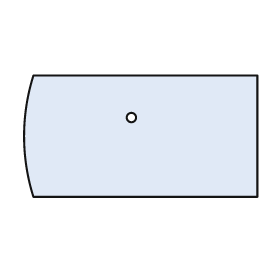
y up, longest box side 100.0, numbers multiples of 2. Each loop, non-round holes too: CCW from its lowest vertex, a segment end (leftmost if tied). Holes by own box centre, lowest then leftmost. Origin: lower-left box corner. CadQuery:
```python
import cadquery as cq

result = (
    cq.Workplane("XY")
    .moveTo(4.0, 0.0)
    .lineTo(100.0, 0.0)
    .lineTo(100.0, 52.0)
    .lineTo(4.0, 52.0)
    .threePointArc((0.0, 26.0), (4.0, 0.0))
    .close()
    .moveTo(46.0, 34.0)
    .circle(2.0)
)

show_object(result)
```